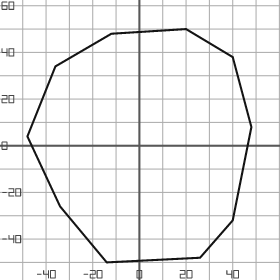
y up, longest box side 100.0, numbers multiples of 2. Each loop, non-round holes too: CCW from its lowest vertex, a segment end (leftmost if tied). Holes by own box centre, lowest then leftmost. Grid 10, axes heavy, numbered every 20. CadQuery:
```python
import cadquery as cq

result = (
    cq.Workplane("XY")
    .moveTo(-14.0, -50.0)
    .lineTo(26.0, -48.0)
    .lineTo(40.0, -32.0)
    .lineTo(48.0, 8.0)
    .lineTo(40.0, 38.0)
    .lineTo(20.0, 50.0)
    .lineTo(-12.0, 48.0)
    .lineTo(-36.0, 34.0)
    .lineTo(-48.0, 4.0)
    .lineTo(-34.0, -26.0)
    .close()
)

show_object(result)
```